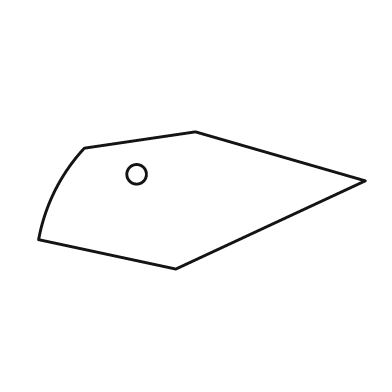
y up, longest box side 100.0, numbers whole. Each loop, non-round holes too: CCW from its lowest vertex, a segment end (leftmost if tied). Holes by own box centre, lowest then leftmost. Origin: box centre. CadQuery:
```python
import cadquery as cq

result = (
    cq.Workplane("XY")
    .moveTo(-8.0, -21.0)
    .lineTo(50.0, 6.0)
    .lineTo(-2.0, 21.0)
    .lineTo(-36.0, 16.0)
    .threePointArc((-45.0, 3.0), (-50.0, -12.0))
    .close()
    .moveTo(-20.0, 8.0)
    .circle(3.0)
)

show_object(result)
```